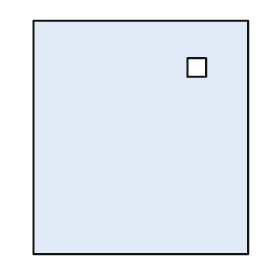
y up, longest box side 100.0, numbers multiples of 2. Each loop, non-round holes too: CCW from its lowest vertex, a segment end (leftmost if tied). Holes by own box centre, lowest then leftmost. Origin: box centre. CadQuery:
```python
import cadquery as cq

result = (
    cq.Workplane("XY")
    .moveTo(-46.0, -50.0)
    .lineTo(46.0, -50.0)
    .lineTo(46.0, 50.0)
    .lineTo(-46.0, 50.0)
    .close()
    .moveTo(20.0, 26.0)
    .lineTo(28.0, 26.0)
    .lineTo(28.0, 34.0)
    .lineTo(20.0, 34.0)
    .close()
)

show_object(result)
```